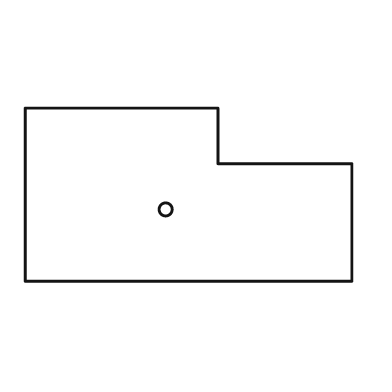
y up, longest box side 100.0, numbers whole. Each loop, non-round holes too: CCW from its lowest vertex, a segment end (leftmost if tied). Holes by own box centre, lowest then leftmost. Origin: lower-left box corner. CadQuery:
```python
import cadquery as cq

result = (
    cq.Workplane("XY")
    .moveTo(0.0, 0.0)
    .lineTo(100.0, 0.0)
    .lineTo(100.0, 36.0)
    .lineTo(59.0, 36.0)
    .lineTo(59.0, 53.0)
    .lineTo(0.0, 53.0)
    .close()
    .moveTo(43.0, 22.0)
    .circle(2.0)
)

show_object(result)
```